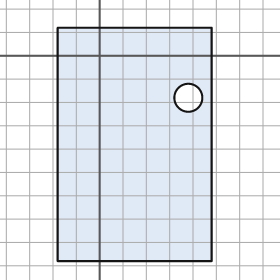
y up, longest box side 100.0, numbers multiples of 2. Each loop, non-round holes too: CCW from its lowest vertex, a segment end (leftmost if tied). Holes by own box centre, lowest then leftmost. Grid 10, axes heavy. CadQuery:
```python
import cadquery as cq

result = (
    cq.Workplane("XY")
    .moveTo(-18.0, -88.0)
    .lineTo(48.0, -88.0)
    .lineTo(48.0, 12.0)
    .lineTo(-18.0, 12.0)
    .close()
    .moveTo(38.0, -18.0)
    .circle(6.0)
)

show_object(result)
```